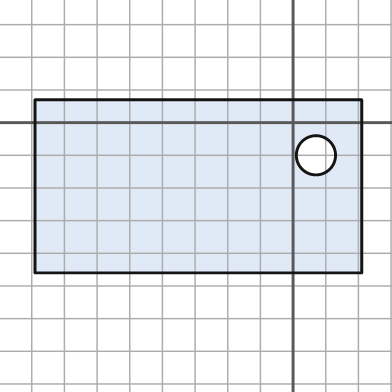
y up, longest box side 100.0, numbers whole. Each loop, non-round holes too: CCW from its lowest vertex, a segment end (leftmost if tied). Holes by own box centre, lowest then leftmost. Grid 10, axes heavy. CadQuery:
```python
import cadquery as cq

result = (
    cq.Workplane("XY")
    .moveTo(-79.0, -46.0)
    .lineTo(21.0, -46.0)
    .lineTo(21.0, 7.0)
    .lineTo(-79.0, 7.0)
    .close()
    .moveTo(7.0, -10.0)
    .circle(6.0)
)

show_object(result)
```